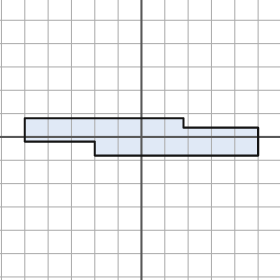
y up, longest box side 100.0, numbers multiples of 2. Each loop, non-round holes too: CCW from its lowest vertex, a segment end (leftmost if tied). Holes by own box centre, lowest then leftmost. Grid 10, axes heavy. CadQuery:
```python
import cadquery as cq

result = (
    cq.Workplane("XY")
    .moveTo(-20.0, -8.0)
    .lineTo(50.0, -8.0)
    .lineTo(50.0, 4.0)
    .lineTo(18.0, 4.0)
    .lineTo(18.0, 8.0)
    .lineTo(-50.0, 8.0)
    .lineTo(-50.0, -2.0)
    .lineTo(-20.0, -2.0)
    .close()
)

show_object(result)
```